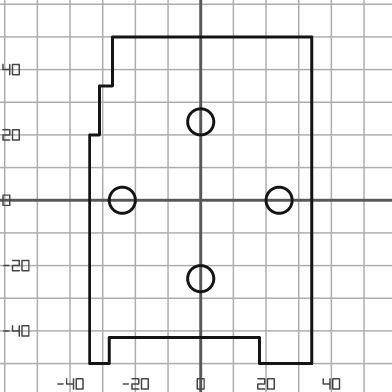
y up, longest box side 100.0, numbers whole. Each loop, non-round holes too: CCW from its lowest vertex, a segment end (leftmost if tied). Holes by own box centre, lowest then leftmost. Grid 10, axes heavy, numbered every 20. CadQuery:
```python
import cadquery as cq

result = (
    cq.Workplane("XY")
    .moveTo(-34.0, -50.0)
    .lineTo(-28.0, -50.0)
    .lineTo(-28.0, -42.0)
    .lineTo(18.0, -42.0)
    .lineTo(18.0, -50.0)
    .lineTo(34.0, -50.0)
    .lineTo(34.0, 50.0)
    .lineTo(-27.0, 50.0)
    .lineTo(-27.0, 35.0)
    .lineTo(-31.0, 35.0)
    .lineTo(-31.0, 20.0)
    .lineTo(-34.0, 20.0)
    .close()
    .moveTo(0.0, -24.0)
    .circle(4.0)
    .moveTo(-24.0, 0.0)
    .circle(4.0)
    .moveTo(24.0, 0.0)
    .circle(4.0)
    .moveTo(0.0, 24.0)
    .circle(4.0)
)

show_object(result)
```